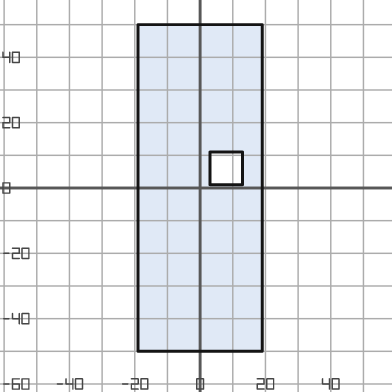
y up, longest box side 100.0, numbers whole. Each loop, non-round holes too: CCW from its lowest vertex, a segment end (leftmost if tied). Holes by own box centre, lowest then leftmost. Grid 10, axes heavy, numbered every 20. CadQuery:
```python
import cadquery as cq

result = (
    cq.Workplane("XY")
    .moveTo(-19.0, -50.0)
    .lineTo(19.0, -50.0)
    .lineTo(19.0, 50.0)
    .lineTo(-19.0, 50.0)
    .close()
    .moveTo(3.0, 1.0)
    .lineTo(13.0, 1.0)
    .lineTo(13.0, 11.0)
    .lineTo(3.0, 11.0)
    .close()
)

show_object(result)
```